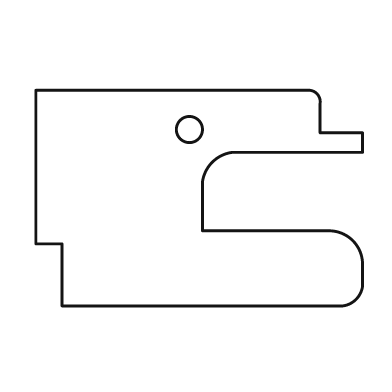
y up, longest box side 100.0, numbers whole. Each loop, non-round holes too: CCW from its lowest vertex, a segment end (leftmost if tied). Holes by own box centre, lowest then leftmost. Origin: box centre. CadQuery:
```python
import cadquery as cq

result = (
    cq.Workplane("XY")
    .moveTo(-42.0, -33.0)
    .lineTo(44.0, -33.0)
    .threePointArc((48.0, -31.0), (50.0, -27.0))
    .lineTo(50.0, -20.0)
    .threePointArc((47.0, -13.0), (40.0, -10.0))
    .lineTo(1.0, -10.0)
    .lineTo(1.0, 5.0)
    .threePointArc((4.0, 11.0), (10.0, 14.0))
    .lineTo(50.0, 14.0)
    .lineTo(50.0, 20.0)
    .lineTo(37.0, 20.0)
    .lineTo(37.0, 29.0)
    .threePointArc((36.0, 32.0), (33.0, 33.0))
    .lineTo(-50.0, 33.0)
    .lineTo(-50.0, -14.0)
    .lineTo(-42.0, -14.0)
    .close()
    .moveTo(-3.0, 21.0)
    .circle(4.0)
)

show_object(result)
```